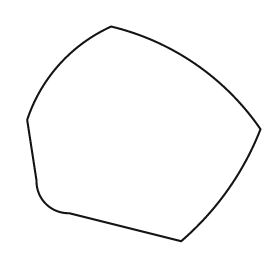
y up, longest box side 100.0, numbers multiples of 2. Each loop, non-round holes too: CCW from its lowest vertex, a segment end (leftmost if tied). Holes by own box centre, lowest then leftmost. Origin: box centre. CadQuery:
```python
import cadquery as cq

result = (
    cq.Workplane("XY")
    .moveTo(16.0, -46.0)
    .threePointArc((36.0, -24.0), (50.0, 2.0))
    .threePointArc((22.0, 30.0), (-14.0, 46.0))
    .threePointArc((-36.0, 30.0), (-50.0, 6.0))
    .lineTo(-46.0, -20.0)
    .threePointArc((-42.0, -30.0), (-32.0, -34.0))
    .close()
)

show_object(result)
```